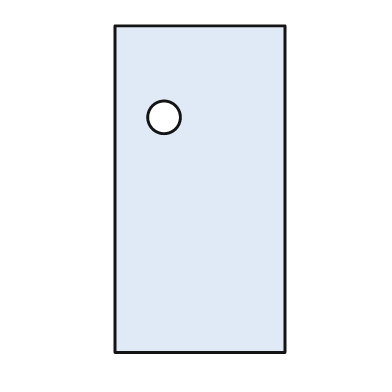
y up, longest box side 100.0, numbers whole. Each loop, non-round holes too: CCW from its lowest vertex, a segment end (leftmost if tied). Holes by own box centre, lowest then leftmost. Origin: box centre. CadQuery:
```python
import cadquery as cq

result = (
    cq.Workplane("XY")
    .moveTo(-26.0, -50.0)
    .lineTo(26.0, -50.0)
    .lineTo(26.0, 50.0)
    .lineTo(-26.0, 50.0)
    .close()
    .moveTo(-11.0, 22.0)
    .circle(5.0)
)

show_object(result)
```